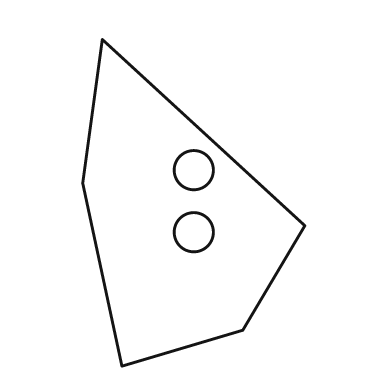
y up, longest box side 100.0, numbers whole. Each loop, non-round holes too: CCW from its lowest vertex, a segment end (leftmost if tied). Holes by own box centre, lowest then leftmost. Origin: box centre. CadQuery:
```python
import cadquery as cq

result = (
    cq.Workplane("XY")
    .moveTo(-22.0, -50.0)
    .lineTo(15.0, -39.0)
    .lineTo(34.0, -7.0)
    .lineTo(-28.0, 50.0)
    .lineTo(-34.0, 6.0)
    .close()
    .moveTo(0.0, -9.0)
    .circle(6.0)
    .moveTo(0.0, 10.0)
    .circle(6.0)
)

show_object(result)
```